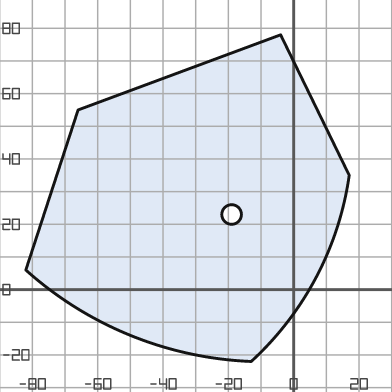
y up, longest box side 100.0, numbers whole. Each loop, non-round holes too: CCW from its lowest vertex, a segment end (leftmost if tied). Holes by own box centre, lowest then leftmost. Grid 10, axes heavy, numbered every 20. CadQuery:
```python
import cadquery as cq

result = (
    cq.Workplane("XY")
    .moveTo(-13.0, -22.0)
    .threePointArc((7.0, 4.0), (17.0, 35.0))
    .lineTo(-4.0, 78.0)
    .lineTo(-66.0, 55.0)
    .lineTo(-82.0, 6.0)
    .threePointArc((-50.0, -14.0), (-13.0, -22.0))
    .close()
    .moveTo(-19.0, 23.0)
    .circle(3.0)
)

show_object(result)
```